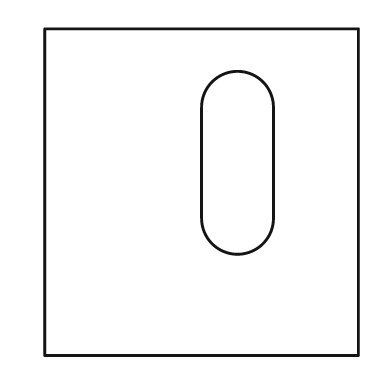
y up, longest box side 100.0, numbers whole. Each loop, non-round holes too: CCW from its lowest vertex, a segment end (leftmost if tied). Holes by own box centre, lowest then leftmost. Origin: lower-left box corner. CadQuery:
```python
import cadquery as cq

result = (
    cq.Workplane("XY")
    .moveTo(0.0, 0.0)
    .lineTo(96.0, 0.0)
    .lineTo(96.0, 100.0)
    .lineTo(0.0, 100.0)
    .close()
    .moveTo(48.0, 42.0)
    .threePointArc((59.0, 31.0), (70.0, 42.0))
    .lineTo(70.0, 76.0)
    .threePointArc((59.0, 87.0), (48.0, 76.0))
    .close()
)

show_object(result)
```